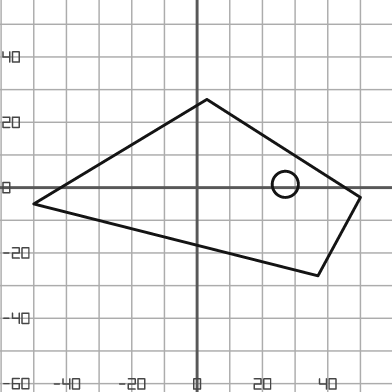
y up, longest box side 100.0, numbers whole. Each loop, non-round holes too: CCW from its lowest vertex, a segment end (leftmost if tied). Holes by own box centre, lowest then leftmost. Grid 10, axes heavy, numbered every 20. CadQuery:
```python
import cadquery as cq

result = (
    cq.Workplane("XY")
    .moveTo(37.0, -27.0)
    .lineTo(50.0, -3.0)
    .lineTo(3.0, 27.0)
    .lineTo(-50.0, -5.0)
    .close()
    .moveTo(27.0, 1.0)
    .circle(4.0)
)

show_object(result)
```